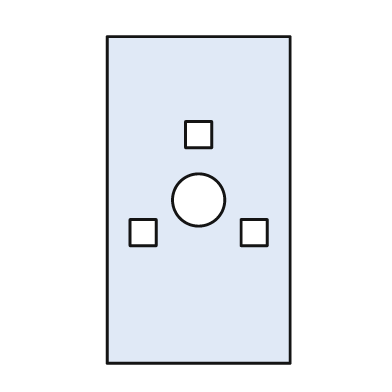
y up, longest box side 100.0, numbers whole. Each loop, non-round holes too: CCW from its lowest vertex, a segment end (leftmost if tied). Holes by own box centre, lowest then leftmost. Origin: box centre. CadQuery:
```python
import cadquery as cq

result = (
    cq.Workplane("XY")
    .moveTo(-28.0, -50.0)
    .lineTo(28.0, -50.0)
    .lineTo(28.0, 50.0)
    .lineTo(-28.0, 50.0)
    .close()
    .moveTo(-21.0, -14.0)
    .lineTo(-13.0, -14.0)
    .lineTo(-13.0, -6.0)
    .lineTo(-21.0, -6.0)
    .close()
    .moveTo(13.0, -14.0)
    .lineTo(21.0, -14.0)
    .lineTo(21.0, -6.0)
    .lineTo(13.0, -6.0)
    .close()
    .moveTo(0.0, 0.0)
    .circle(8.0)
    .moveTo(-4.0, 16.0)
    .lineTo(4.0, 16.0)
    .lineTo(4.0, 24.0)
    .lineTo(-4.0, 24.0)
    .close()
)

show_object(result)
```